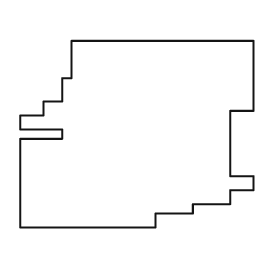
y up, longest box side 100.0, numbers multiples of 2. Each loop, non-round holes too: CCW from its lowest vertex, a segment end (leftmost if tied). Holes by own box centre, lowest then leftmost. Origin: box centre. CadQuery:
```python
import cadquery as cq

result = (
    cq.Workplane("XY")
    .moveTo(-50.0, -40.0)
    .lineTo(8.0, -40.0)
    .lineTo(8.0, -34.0)
    .lineTo(24.0, -34.0)
    .lineTo(24.0, -30.0)
    .lineTo(40.0, -30.0)
    .lineTo(40.0, -24.0)
    .lineTo(50.0, -24.0)
    .lineTo(50.0, -18.0)
    .lineTo(40.0, -18.0)
    .lineTo(40.0, 10.0)
    .lineTo(50.0, 10.0)
    .lineTo(50.0, 40.0)
    .lineTo(-28.0, 40.0)
    .lineTo(-28.0, 24.0)
    .lineTo(-32.0, 24.0)
    .lineTo(-32.0, 14.0)
    .lineTo(-40.0, 14.0)
    .lineTo(-40.0, 8.0)
    .lineTo(-50.0, 8.0)
    .lineTo(-50.0, 2.0)
    .lineTo(-32.0, 2.0)
    .lineTo(-32.0, -2.0)
    .lineTo(-50.0, -2.0)
    .close()
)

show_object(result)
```